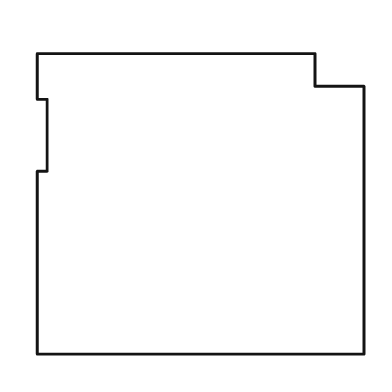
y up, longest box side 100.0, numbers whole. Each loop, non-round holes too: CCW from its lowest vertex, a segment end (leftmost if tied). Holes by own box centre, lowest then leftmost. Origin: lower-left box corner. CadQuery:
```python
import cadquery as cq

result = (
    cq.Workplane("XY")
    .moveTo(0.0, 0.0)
    .lineTo(100.0, 0.0)
    .lineTo(100.0, 82.0)
    .lineTo(85.0, 82.0)
    .lineTo(85.0, 92.0)
    .lineTo(0.0, 92.0)
    .lineTo(0.0, 78.0)
    .lineTo(3.0, 78.0)
    .lineTo(3.0, 56.0)
    .lineTo(0.0, 56.0)
    .close()
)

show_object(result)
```